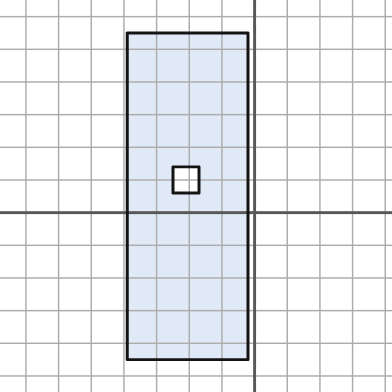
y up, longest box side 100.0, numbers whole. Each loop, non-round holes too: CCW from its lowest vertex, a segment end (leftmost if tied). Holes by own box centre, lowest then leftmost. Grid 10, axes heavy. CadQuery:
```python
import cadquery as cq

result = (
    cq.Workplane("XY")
    .moveTo(-39.0, -45.0)
    .lineTo(-2.0, -45.0)
    .lineTo(-2.0, 55.0)
    .lineTo(-39.0, 55.0)
    .close()
    .moveTo(-25.0, 6.0)
    .lineTo(-17.0, 6.0)
    .lineTo(-17.0, 14.0)
    .lineTo(-25.0, 14.0)
    .close()
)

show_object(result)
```